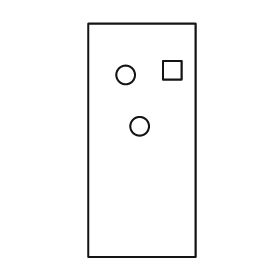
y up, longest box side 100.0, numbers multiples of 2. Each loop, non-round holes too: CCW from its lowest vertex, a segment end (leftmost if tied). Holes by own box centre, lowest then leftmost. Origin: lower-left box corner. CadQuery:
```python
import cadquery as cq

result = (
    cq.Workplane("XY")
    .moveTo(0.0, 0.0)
    .lineTo(46.0, 0.0)
    .lineTo(46.0, 100.0)
    .lineTo(0.0, 100.0)
    .close()
    .moveTo(22.0, 56.0)
    .circle(4.0)
    .moveTo(16.0, 78.0)
    .circle(4.0)
    .moveTo(32.0, 76.0)
    .lineTo(40.0, 76.0)
    .lineTo(40.0, 84.0)
    .lineTo(32.0, 84.0)
    .close()
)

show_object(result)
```